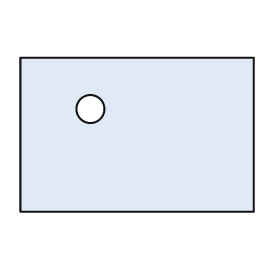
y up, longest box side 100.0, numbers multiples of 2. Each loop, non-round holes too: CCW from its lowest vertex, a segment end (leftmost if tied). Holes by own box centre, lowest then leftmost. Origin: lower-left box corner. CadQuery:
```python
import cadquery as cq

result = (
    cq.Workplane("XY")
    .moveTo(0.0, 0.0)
    .lineTo(100.0, 0.0)
    .lineTo(100.0, 66.0)
    .lineTo(0.0, 66.0)
    .close()
    .moveTo(30.0, 44.0)
    .circle(6.0)
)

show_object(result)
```